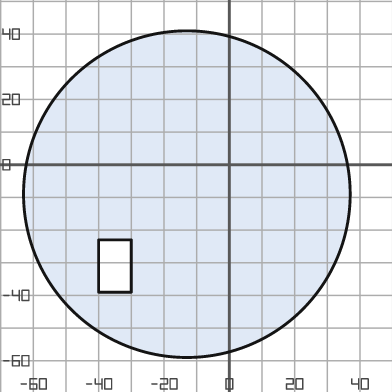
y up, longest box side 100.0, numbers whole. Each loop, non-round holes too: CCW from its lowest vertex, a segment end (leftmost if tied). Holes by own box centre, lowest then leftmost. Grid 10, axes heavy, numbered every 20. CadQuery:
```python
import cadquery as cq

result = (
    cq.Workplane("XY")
    .moveTo(-13.0, -9.0)
    .circle(50.0)
    .moveTo(-40.0, -39.0)
    .lineTo(-30.0, -39.0)
    .lineTo(-30.0, -23.0)
    .lineTo(-40.0, -23.0)
    .close()
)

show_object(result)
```